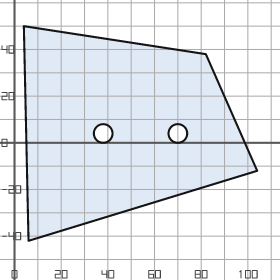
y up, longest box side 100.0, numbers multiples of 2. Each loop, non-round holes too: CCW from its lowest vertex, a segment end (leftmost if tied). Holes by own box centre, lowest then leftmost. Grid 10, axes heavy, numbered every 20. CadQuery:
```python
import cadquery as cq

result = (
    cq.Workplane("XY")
    .moveTo(6.0, -42.0)
    .lineTo(104.0, -12.0)
    .lineTo(82.0, 38.0)
    .lineTo(4.0, 50.0)
    .close()
    .moveTo(38.0, 4.0)
    .circle(4.0)
    .moveTo(70.0, 4.0)
    .circle(4.0)
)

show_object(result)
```